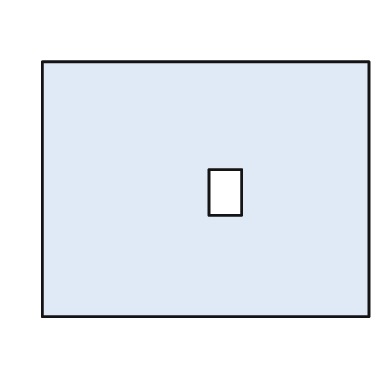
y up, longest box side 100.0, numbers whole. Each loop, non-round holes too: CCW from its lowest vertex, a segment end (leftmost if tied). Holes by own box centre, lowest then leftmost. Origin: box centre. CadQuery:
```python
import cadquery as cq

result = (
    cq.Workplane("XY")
    .moveTo(-50.0, -39.0)
    .lineTo(50.0, -39.0)
    .lineTo(50.0, 39.0)
    .lineTo(-50.0, 39.0)
    .close()
    .moveTo(1.0, -8.0)
    .lineTo(11.0, -8.0)
    .lineTo(11.0, 6.0)
    .lineTo(1.0, 6.0)
    .close()
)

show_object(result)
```